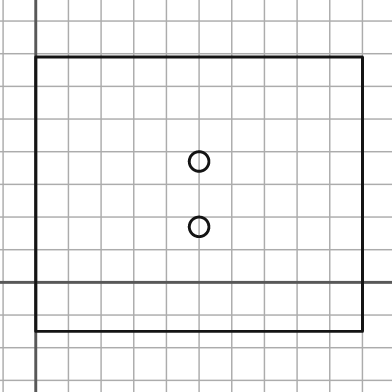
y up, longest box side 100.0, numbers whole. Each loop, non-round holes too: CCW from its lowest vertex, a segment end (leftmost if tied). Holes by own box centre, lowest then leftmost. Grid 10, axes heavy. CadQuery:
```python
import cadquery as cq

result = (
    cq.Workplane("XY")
    .moveTo(0.0, -15.0)
    .lineTo(100.0, -15.0)
    .lineTo(100.0, 69.0)
    .lineTo(0.0, 69.0)
    .close()
    .moveTo(50.0, 17.0)
    .circle(3.0)
    .moveTo(50.0, 37.0)
    .circle(3.0)
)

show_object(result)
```